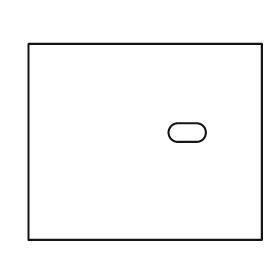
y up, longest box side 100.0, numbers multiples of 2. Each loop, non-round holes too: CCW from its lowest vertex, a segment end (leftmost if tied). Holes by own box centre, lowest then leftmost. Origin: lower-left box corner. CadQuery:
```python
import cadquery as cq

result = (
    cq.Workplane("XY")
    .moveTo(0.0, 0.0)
    .lineTo(100.0, 0.0)
    .lineTo(100.0, 84.0)
    .lineTo(0.0, 84.0)
    .close()
    .moveTo(64.0, 42.0)
    .lineTo(72.0, 42.0)
    .threePointArc((76.0, 46.0), (72.0, 50.0))
    .lineTo(64.0, 50.0)
    .threePointArc((60.0, 46.0), (64.0, 42.0))
    .close()
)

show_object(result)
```